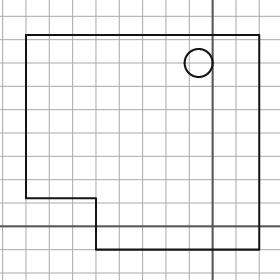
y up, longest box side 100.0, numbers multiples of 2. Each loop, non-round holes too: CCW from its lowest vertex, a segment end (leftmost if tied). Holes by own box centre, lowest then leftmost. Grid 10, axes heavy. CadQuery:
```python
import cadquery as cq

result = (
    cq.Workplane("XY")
    .moveTo(-50.0, -10.0)
    .lineTo(20.0, -10.0)
    .lineTo(20.0, 82.0)
    .lineTo(-80.0, 82.0)
    .lineTo(-80.0, 12.0)
    .lineTo(-50.0, 12.0)
    .close()
    .moveTo(-6.0, 70.0)
    .circle(6.0)
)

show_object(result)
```